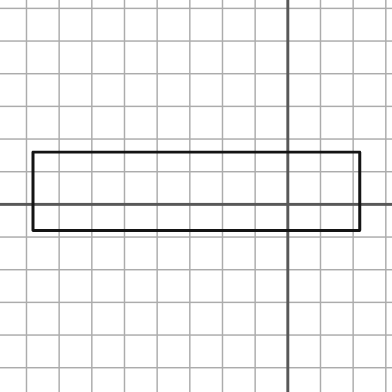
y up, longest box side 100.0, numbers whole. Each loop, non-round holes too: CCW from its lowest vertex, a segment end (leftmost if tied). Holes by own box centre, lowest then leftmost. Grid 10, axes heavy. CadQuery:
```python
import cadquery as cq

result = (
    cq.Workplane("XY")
    .moveTo(-78.0, -8.0)
    .lineTo(22.0, -8.0)
    .lineTo(22.0, 16.0)
    .lineTo(-78.0, 16.0)
    .close()
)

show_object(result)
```